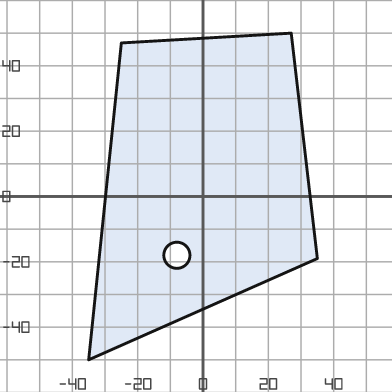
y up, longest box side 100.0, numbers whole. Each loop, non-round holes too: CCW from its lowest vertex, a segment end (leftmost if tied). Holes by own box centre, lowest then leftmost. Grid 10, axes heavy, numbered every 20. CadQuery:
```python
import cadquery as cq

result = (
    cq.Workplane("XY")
    .moveTo(-35.0, -50.0)
    .lineTo(35.0, -19.0)
    .lineTo(27.0, 50.0)
    .lineTo(-25.0, 47.0)
    .close()
    .moveTo(-8.0, -18.0)
    .circle(4.0)
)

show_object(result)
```